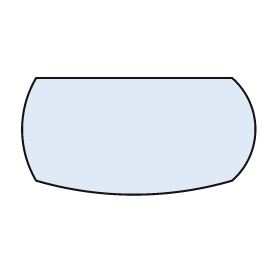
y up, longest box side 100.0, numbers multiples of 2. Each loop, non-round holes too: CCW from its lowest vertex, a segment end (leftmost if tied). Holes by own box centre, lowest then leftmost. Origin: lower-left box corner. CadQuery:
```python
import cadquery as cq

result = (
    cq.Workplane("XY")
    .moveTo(6.0, 6.0)
    .threePointArc((48.0, 0.0), (90.0, 6.0))
    .threePointArc((100.0, 28.0), (90.0, 50.0))
    .lineTo(6.0, 50.0)
    .threePointArc((0.0, 28.0), (6.0, 6.0))
    .close()
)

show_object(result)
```